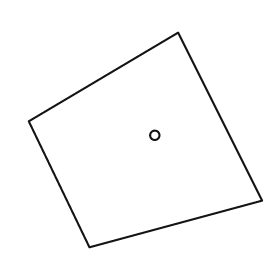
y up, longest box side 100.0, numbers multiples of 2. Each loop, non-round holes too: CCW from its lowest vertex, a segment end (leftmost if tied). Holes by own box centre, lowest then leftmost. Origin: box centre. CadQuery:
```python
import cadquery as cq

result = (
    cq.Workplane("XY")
    .moveTo(-24.0, -46.0)
    .lineTo(50.0, -26.0)
    .lineTo(14.0, 46.0)
    .lineTo(-50.0, 8.0)
    .close()
    .moveTo(4.0, 2.0)
    .circle(2.0)
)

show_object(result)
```